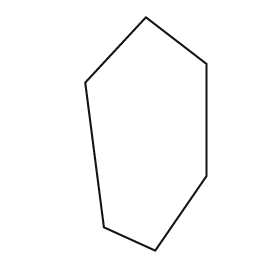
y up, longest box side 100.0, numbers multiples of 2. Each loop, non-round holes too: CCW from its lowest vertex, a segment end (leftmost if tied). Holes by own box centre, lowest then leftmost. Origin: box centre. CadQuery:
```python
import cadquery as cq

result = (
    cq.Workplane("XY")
    .moveTo(4.0, -50.0)
    .lineTo(26.0, -18.0)
    .lineTo(26.0, 30.0)
    .lineTo(0.0, 50.0)
    .lineTo(-26.0, 22.0)
    .lineTo(-18.0, -40.0)
    .close()
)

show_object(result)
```